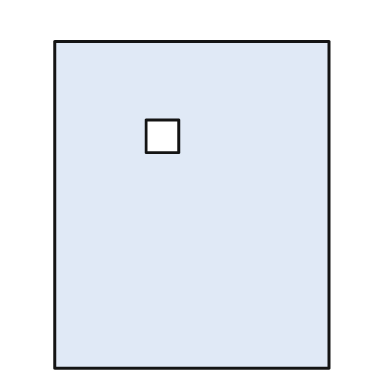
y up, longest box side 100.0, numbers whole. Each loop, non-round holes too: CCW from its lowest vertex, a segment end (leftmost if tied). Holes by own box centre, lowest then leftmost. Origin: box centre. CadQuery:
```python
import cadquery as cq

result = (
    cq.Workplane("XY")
    .moveTo(-42.0, -50.0)
    .lineTo(42.0, -50.0)
    .lineTo(42.0, 50.0)
    .lineTo(-42.0, 50.0)
    .close()
    .moveTo(-14.0, 16.0)
    .lineTo(-4.0, 16.0)
    .lineTo(-4.0, 26.0)
    .lineTo(-14.0, 26.0)
    .close()
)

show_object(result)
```